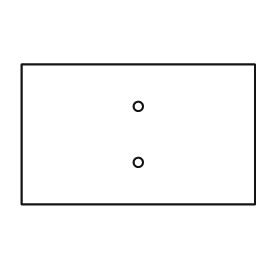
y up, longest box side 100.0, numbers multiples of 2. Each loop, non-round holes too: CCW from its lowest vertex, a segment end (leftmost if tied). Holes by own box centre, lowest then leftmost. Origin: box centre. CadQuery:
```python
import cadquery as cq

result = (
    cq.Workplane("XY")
    .moveTo(-50.0, -30.0)
    .lineTo(50.0, -30.0)
    .lineTo(50.0, 30.0)
    .lineTo(-50.0, 30.0)
    .close()
    .moveTo(0.0, -12.0)
    .circle(2.0)
    .moveTo(0.0, 12.0)
    .circle(2.0)
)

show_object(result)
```